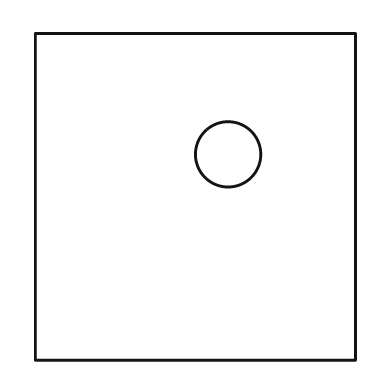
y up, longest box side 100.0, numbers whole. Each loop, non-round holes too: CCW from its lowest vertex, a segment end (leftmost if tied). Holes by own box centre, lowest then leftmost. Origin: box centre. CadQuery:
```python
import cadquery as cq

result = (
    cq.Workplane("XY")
    .moveTo(-49.0, -50.0)
    .lineTo(49.0, -50.0)
    .lineTo(49.0, 50.0)
    .lineTo(-49.0, 50.0)
    .close()
    .moveTo(10.0, 13.0)
    .circle(10.0)
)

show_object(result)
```